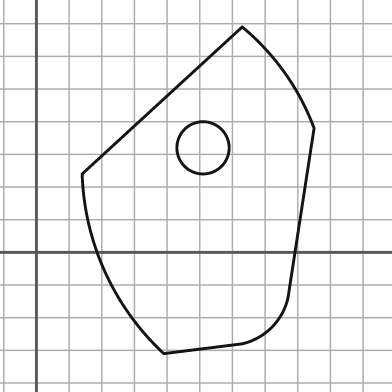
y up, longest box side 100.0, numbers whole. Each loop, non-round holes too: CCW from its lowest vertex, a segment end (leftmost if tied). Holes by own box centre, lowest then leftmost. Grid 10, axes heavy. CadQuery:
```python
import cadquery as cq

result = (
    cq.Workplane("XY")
    .moveTo(39.0, -31.0)
    .lineTo(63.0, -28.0)
    .threePointArc((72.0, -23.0), (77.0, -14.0))
    .lineTo(85.0, 38.0)
    .threePointArc((76.0, 55.0), (63.0, 69.0))
    .lineTo(14.0, 24.0)
    .threePointArc((21.0, -6.0), (39.0, -31.0))
    .close()
    .moveTo(51.0, 32.0)
    .circle(8.0)
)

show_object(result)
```